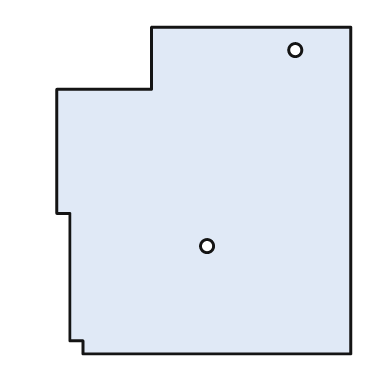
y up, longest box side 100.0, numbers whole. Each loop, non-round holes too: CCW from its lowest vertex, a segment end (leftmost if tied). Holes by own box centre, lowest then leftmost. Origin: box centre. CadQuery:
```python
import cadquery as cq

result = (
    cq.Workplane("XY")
    .moveTo(-37.0, -50.0)
    .lineTo(45.0, -50.0)
    .lineTo(45.0, 50.0)
    .lineTo(-16.0, 50.0)
    .lineTo(-16.0, 31.0)
    .lineTo(-45.0, 31.0)
    .lineTo(-45.0, -7.0)
    .lineTo(-41.0, -7.0)
    .lineTo(-41.0, -46.0)
    .lineTo(-37.0, -46.0)
    .close()
    .moveTo(1.0, -17.0)
    .circle(2.0)
    .moveTo(28.0, 43.0)
    .circle(2.0)
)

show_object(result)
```